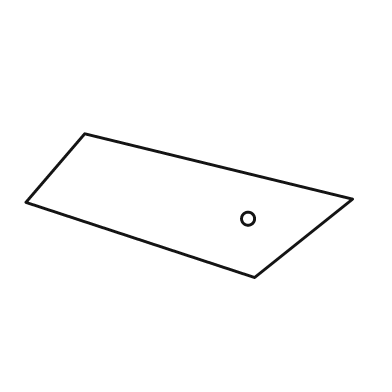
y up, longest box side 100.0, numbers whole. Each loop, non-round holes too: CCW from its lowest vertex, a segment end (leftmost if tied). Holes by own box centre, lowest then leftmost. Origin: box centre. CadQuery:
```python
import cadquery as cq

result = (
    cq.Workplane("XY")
    .moveTo(20.0, -22.0)
    .lineTo(50.0, 2.0)
    .lineTo(-32.0, 22.0)
    .lineTo(-50.0, 1.0)
    .close()
    .moveTo(18.0, -4.0)
    .circle(2.0)
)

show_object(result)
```